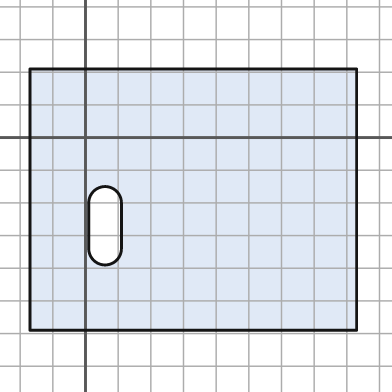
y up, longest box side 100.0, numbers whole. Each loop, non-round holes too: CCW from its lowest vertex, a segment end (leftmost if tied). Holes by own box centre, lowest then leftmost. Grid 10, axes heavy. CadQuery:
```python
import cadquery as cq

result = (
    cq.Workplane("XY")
    .moveTo(-17.0, -59.0)
    .lineTo(83.0, -59.0)
    .lineTo(83.0, 21.0)
    .lineTo(-17.0, 21.0)
    .close()
    .moveTo(1.0, -34.0)
    .threePointArc((6.0, -39.0), (11.0, -34.0))
    .lineTo(11.0, -20.0)
    .threePointArc((6.0, -15.0), (1.0, -20.0))
    .close()
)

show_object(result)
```